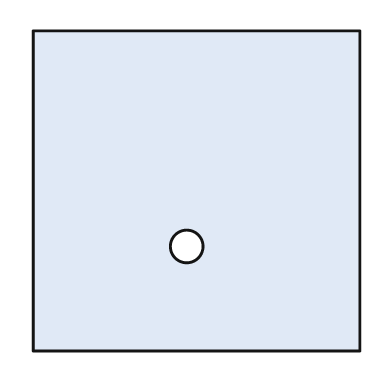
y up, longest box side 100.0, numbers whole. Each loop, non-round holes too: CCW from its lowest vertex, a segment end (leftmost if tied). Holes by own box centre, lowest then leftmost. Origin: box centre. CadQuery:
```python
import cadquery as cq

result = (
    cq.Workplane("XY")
    .moveTo(-50.0, -49.0)
    .lineTo(50.0, -49.0)
    .lineTo(50.0, 49.0)
    .lineTo(-50.0, 49.0)
    .close()
    .moveTo(-3.0, -17.0)
    .circle(5.0)
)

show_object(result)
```